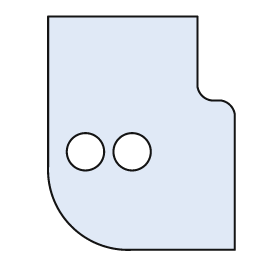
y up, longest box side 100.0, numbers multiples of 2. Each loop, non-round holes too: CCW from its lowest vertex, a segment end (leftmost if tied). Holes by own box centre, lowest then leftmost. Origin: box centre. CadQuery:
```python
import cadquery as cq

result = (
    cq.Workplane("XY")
    .moveTo(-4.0, -50.0)
    .lineTo(40.0, -50.0)
    .lineTo(40.0, 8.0)
    .threePointArc((38.0, 12.0), (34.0, 14.0))
    .lineTo(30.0, 14.0)
    .threePointArc((26.0, 16.0), (24.0, 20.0))
    .lineTo(24.0, 50.0)
    .lineTo(-40.0, 50.0)
    .lineTo(-40.0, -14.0)
    .threePointArc((-30.0, -40.0), (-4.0, -50.0))
    .close()
    .moveTo(-24.0, -8.0)
    .circle(8.0)
    .moveTo(-4.0, -8.0)
    .circle(8.0)
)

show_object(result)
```